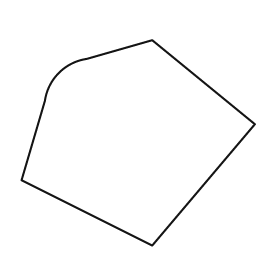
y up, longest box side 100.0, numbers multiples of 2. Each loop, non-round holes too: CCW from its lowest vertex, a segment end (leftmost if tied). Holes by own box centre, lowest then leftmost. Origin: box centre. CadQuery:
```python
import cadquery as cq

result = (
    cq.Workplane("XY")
    .moveTo(6.0, -44.0)
    .lineTo(50.0, 8.0)
    .lineTo(6.0, 44.0)
    .lineTo(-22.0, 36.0)
    .threePointArc((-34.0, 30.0), (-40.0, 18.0))
    .lineTo(-50.0, -16.0)
    .close()
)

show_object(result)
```